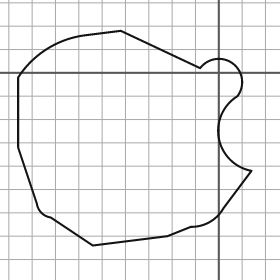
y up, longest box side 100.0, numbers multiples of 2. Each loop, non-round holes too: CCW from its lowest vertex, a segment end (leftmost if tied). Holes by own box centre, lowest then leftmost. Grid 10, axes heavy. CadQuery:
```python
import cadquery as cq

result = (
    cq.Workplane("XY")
    .moveTo(-54.0, -74.0)
    .lineTo(-22.0, -70.0)
    .lineTo(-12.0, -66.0)
    .threePointArc((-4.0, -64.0), (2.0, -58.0))
    .lineTo(14.0, -42.0)
    .threePointArc((0.0, -28.0), (8.0, -10.0))
    .threePointArc((6.0, 4.0), (-8.0, 2.0))
    .lineTo(-42.0, 18.0)
    .lineTo(-58.0, 16.0)
    .threePointArc((-74.0, 10.0), (-86.0, -2.0))
    .lineTo(-86.0, -32.0)
    .lineTo(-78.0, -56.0)
    .threePointArc((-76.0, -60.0), (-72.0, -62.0))
    .close()
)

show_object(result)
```